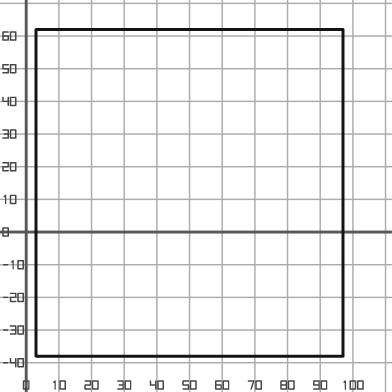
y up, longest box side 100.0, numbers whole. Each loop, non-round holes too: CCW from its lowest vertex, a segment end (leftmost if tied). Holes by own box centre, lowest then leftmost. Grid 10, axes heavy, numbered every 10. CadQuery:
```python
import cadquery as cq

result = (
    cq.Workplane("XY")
    .moveTo(3.0, -38.0)
    .lineTo(97.0, -38.0)
    .lineTo(97.0, 62.0)
    .lineTo(3.0, 62.0)
    .close()
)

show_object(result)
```